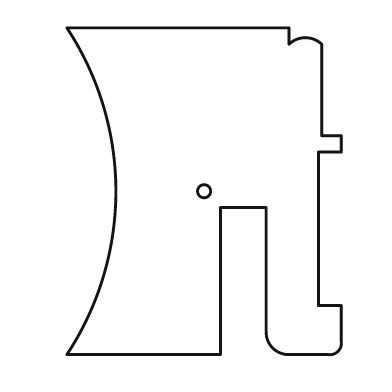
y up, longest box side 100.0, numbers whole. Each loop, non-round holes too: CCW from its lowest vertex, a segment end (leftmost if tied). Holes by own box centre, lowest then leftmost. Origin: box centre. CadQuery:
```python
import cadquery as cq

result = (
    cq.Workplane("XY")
    .moveTo(-42.0, -50.0)
    .lineTo(5.0, -50.0)
    .lineTo(5.0, -5.0)
    .lineTo(19.0, -5.0)
    .lineTo(19.0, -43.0)
    .threePointArc((21.0, -48.0), (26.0, -50.0))
    .lineTo(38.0, -50.0)
    .threePointArc((41.0, -49.0), (42.0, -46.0))
    .lineTo(42.0, -35.0)
    .lineTo(35.0, -35.0)
    .lineTo(35.0, 12.0)
    .lineTo(42.0, 12.0)
    .lineTo(42.0, 17.0)
    .lineTo(36.0, 17.0)
    .lineTo(36.0, 45.0)
    .threePointArc((31.0, 47.0), (26.0, 45.0))
    .lineTo(26.0, 50.0)
    .lineTo(-42.0, 50.0)
    .threePointArc((-27.0, 0.0), (-42.0, -50.0))
    .close()
    .moveTo(0.0, 0.0)
    .circle(2.0)
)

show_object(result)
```